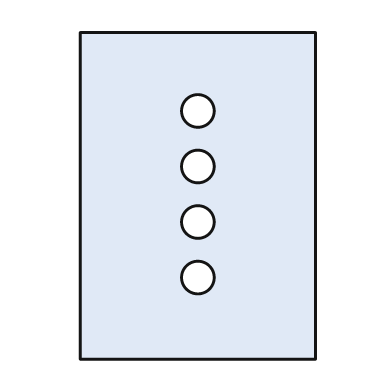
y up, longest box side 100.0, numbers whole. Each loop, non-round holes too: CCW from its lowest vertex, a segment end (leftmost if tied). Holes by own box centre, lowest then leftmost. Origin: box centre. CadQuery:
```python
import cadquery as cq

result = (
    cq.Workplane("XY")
    .moveTo(-36.0, -50.0)
    .lineTo(36.0, -50.0)
    .lineTo(36.0, 50.0)
    .lineTo(-36.0, 50.0)
    .close()
    .moveTo(0.0, -25.0)
    .circle(5.0)
    .moveTo(0.0, -8.0)
    .circle(5.0)
    .moveTo(0.0, 9.0)
    .circle(5.0)
    .moveTo(0.0, 26.0)
    .circle(5.0)
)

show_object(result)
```